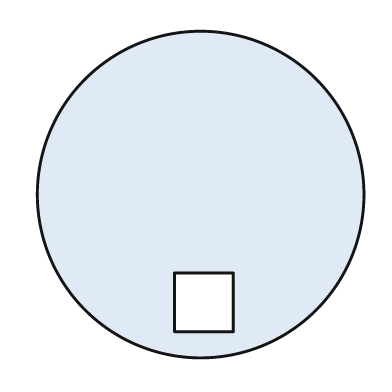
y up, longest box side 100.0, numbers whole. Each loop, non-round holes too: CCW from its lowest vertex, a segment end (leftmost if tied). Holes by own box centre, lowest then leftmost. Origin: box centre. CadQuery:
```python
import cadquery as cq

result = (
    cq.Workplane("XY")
    .moveTo(0.0, 0.0)
    .circle(50.0)
    .moveTo(-8.0, -42.0)
    .lineTo(10.0, -42.0)
    .lineTo(10.0, -24.0)
    .lineTo(-8.0, -24.0)
    .close()
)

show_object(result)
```